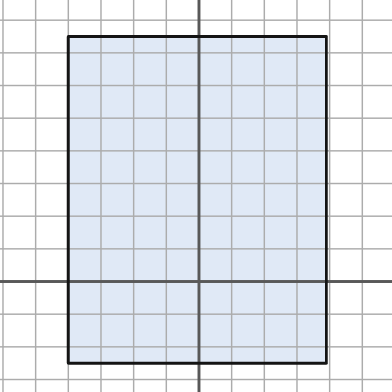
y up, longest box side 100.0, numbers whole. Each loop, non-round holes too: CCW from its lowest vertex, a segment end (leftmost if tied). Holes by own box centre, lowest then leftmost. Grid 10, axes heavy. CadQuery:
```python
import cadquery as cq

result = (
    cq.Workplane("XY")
    .moveTo(-40.0, -25.0)
    .lineTo(39.0, -25.0)
    .lineTo(39.0, 75.0)
    .lineTo(-40.0, 75.0)
    .close()
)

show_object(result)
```